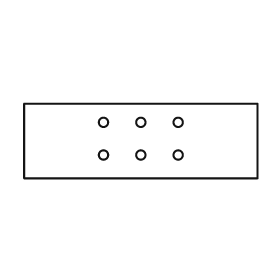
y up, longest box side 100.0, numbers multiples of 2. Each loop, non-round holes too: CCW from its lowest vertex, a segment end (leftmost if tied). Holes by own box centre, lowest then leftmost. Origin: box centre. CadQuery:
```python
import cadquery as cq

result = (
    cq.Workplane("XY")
    .moveTo(-50.0, -16.0)
    .lineTo(50.0, -16.0)
    .lineTo(50.0, 16.0)
    .lineTo(-50.0, 16.0)
    .close()
    .moveTo(-16.0, -6.0)
    .circle(2.0)
    .moveTo(0.0, -6.0)
    .circle(2.0)
    .moveTo(16.0, -6.0)
    .circle(2.0)
    .moveTo(-16.0, 8.0)
    .circle(2.0)
    .moveTo(0.0, 8.0)
    .circle(2.0)
    .moveTo(16.0, 8.0)
    .circle(2.0)
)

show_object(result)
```